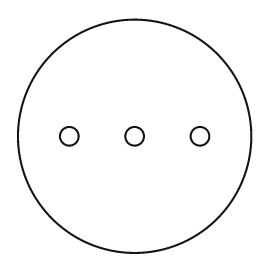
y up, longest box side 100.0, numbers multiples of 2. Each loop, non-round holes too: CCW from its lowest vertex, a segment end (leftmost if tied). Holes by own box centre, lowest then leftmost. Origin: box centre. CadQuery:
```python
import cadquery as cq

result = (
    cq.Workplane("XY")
    .moveTo(0.0, 0.0)
    .circle(50.0)
    .moveTo(-28.0, 0.0)
    .circle(4.0)
    .moveTo(0.0, 0.0)
    .circle(4.0)
    .moveTo(28.0, 0.0)
    .circle(4.0)
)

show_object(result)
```